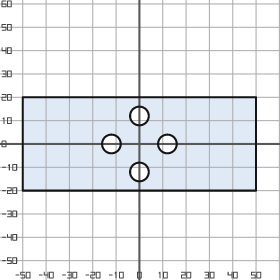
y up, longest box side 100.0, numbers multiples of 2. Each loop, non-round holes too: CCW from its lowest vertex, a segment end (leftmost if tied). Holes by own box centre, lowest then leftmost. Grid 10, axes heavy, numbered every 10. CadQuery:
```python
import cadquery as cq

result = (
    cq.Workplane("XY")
    .moveTo(-50.0, -20.0)
    .lineTo(50.0, -20.0)
    .lineTo(50.0, 20.0)
    .lineTo(-50.0, 20.0)
    .close()
    .moveTo(0.0, -12.0)
    .circle(4.0)
    .moveTo(-12.0, 0.0)
    .circle(4.0)
    .moveTo(12.0, 0.0)
    .circle(4.0)
    .moveTo(0.0, 12.0)
    .circle(4.0)
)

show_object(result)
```